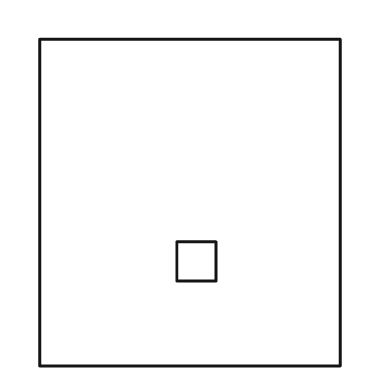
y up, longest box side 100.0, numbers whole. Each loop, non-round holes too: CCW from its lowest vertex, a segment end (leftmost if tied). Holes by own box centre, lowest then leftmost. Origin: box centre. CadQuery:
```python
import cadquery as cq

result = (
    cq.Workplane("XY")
    .moveTo(-46.0, -50.0)
    .lineTo(46.0, -50.0)
    .lineTo(46.0, 50.0)
    .lineTo(-46.0, 50.0)
    .close()
    .moveTo(-4.0, -24.0)
    .lineTo(8.0, -24.0)
    .lineTo(8.0, -12.0)
    .lineTo(-4.0, -12.0)
    .close()
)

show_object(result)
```